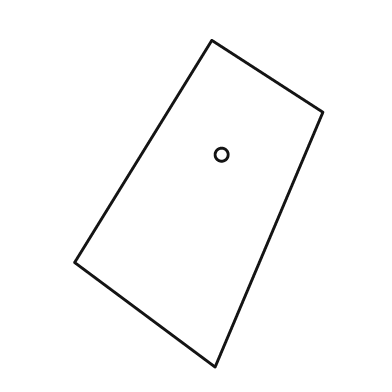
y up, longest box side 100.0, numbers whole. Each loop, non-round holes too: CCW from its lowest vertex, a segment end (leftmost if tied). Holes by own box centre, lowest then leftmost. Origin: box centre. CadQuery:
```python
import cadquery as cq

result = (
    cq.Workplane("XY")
    .moveTo(5.0, -50.0)
    .lineTo(38.0, 28.0)
    .lineTo(4.0, 50.0)
    .lineTo(-38.0, -18.0)
    .close()
    .moveTo(7.0, 15.0)
    .circle(2.0)
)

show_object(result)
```